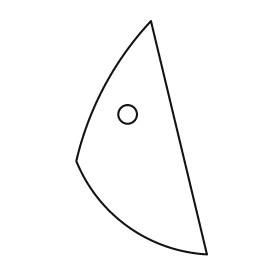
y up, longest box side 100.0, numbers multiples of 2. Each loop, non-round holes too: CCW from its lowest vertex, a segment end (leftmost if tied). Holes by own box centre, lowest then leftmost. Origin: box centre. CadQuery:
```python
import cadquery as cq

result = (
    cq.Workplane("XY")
    .moveTo(28.0, -50.0)
    .lineTo(4.0, 50.0)
    .threePointArc((-16.0, 22.0), (-28.0, -10.0))
    .threePointArc((-6.0, -38.0), (28.0, -50.0))
    .close()
    .moveTo(-6.0, 10.0)
    .circle(4.0)
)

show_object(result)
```